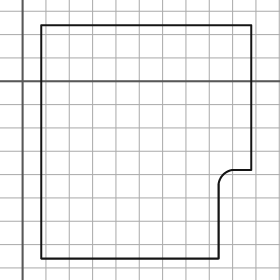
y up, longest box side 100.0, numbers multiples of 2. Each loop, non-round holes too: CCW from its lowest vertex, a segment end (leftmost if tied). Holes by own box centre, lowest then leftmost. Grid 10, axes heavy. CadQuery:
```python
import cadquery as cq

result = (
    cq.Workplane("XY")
    .moveTo(8.0, -76.0)
    .lineTo(84.0, -76.0)
    .lineTo(84.0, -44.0)
    .threePointArc((86.0, -40.0), (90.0, -38.0))
    .lineTo(98.0, -38.0)
    .lineTo(98.0, 24.0)
    .lineTo(8.0, 24.0)
    .close()
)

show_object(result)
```